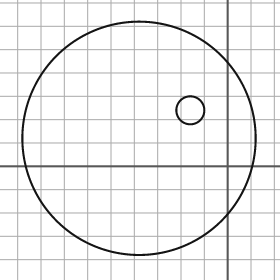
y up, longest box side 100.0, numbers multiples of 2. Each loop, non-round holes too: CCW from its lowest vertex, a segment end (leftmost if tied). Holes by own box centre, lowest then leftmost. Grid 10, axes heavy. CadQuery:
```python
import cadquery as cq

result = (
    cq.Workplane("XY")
    .moveTo(-38.0, 12.0)
    .circle(50.0)
    .moveTo(-16.0, 24.0)
    .circle(6.0)
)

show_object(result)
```